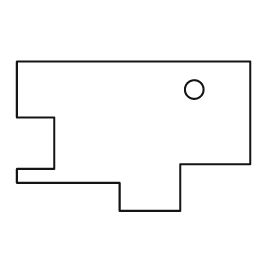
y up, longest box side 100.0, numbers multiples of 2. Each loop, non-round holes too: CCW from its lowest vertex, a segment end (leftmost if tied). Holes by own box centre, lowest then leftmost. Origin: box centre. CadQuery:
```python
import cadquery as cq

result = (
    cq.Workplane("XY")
    .moveTo(-6.0, -32.0)
    .lineTo(20.0, -32.0)
    .lineTo(20.0, -12.0)
    .lineTo(50.0, -12.0)
    .lineTo(50.0, 32.0)
    .lineTo(-50.0, 32.0)
    .lineTo(-50.0, 8.0)
    .lineTo(-34.0, 8.0)
    .lineTo(-34.0, -14.0)
    .lineTo(-50.0, -14.0)
    .lineTo(-50.0, -20.0)
    .lineTo(-6.0, -20.0)
    .close()
    .moveTo(26.0, 20.0)
    .circle(4.0)
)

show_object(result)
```